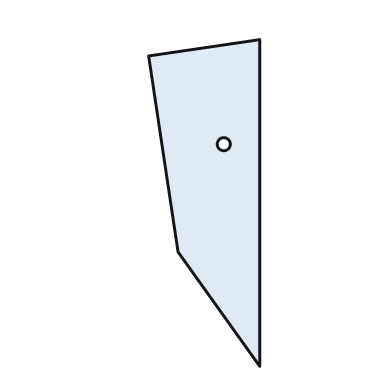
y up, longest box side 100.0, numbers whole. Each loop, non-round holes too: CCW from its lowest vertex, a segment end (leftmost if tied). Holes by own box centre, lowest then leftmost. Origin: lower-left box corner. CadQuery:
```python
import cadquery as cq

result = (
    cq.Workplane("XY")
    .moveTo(34.0, 0.0)
    .lineTo(34.0, 100.0)
    .lineTo(0.0, 95.0)
    .lineTo(9.0, 35.0)
    .close()
    .moveTo(23.0, 68.0)
    .circle(2.0)
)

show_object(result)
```